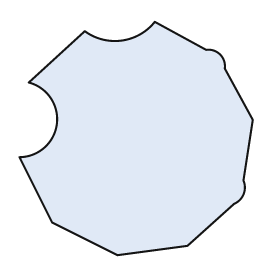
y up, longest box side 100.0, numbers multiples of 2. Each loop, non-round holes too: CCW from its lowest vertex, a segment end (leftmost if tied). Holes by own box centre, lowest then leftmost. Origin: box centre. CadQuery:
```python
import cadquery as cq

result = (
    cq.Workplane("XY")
    .moveTo(-8.0, -50.0)
    .lineTo(22.0, -46.0)
    .lineTo(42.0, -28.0)
    .threePointArc((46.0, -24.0), (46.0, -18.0))
    .lineTo(50.0, 8.0)
    .lineTo(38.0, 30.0)
    .threePointArc((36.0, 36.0), (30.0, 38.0))
    .lineTo(8.0, 50.0)
    .threePointArc((-6.0, 42.0), (-22.0, 46.0))
    .lineTo(-46.0, 24.0)
    .threePointArc((-34.0, 6.0), (-50.0, -8.0))
    .lineTo(-36.0, -36.0)
    .close()
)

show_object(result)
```